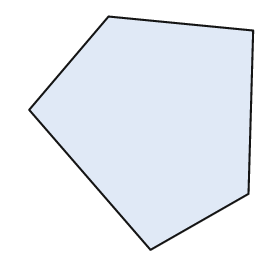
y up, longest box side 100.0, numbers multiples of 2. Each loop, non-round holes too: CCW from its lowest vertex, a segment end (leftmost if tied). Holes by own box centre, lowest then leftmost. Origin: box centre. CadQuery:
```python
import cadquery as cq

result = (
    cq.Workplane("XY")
    .moveTo(4.0, -50.0)
    .lineTo(46.0, -26.0)
    .lineTo(48.0, 44.0)
    .lineTo(-14.0, 50.0)
    .lineTo(-48.0, 10.0)
    .close()
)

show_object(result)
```